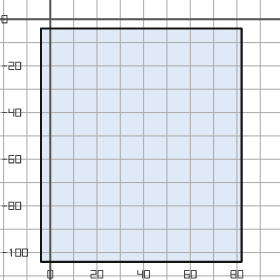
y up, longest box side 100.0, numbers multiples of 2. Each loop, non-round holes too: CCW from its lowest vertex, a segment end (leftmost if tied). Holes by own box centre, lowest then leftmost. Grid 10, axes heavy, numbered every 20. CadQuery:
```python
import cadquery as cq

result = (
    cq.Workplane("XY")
    .moveTo(-4.0, -104.0)
    .lineTo(82.0, -104.0)
    .lineTo(82.0, -4.0)
    .lineTo(-4.0, -4.0)
    .close()
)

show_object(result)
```